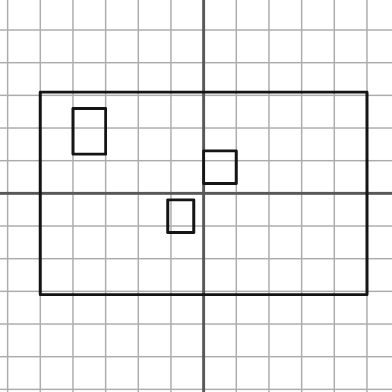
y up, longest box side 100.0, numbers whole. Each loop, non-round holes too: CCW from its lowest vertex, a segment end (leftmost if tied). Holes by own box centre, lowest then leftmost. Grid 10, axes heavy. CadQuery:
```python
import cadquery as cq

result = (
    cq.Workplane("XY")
    .moveTo(-50.0, -31.0)
    .lineTo(50.0, -31.0)
    .lineTo(50.0, 31.0)
    .lineTo(-50.0, 31.0)
    .close()
    .moveTo(-11.0, -12.0)
    .lineTo(-3.0, -12.0)
    .lineTo(-3.0, -2.0)
    .lineTo(-11.0, -2.0)
    .close()
    .moveTo(0.0, 3.0)
    .lineTo(10.0, 3.0)
    .lineTo(10.0, 13.0)
    .lineTo(0.0, 13.0)
    .close()
    .moveTo(-40.0, 12.0)
    .lineTo(-30.0, 12.0)
    .lineTo(-30.0, 26.0)
    .lineTo(-40.0, 26.0)
    .close()
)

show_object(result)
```